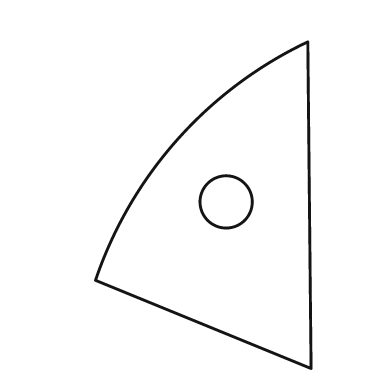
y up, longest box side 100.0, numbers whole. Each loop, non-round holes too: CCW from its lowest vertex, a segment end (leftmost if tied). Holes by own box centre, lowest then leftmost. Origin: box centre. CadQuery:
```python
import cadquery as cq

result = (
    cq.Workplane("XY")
    .moveTo(33.0, -50.0)
    .lineTo(32.0, 50.0)
    .threePointArc((-8.0, 20.0), (-33.0, -23.0))
    .close()
    .moveTo(7.0, 1.0)
    .circle(8.0)
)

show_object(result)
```